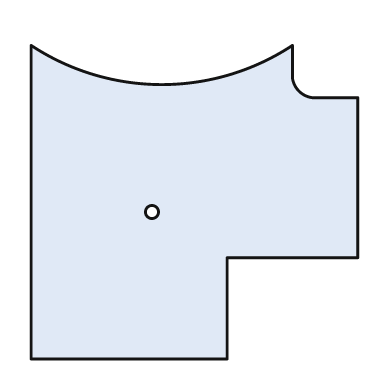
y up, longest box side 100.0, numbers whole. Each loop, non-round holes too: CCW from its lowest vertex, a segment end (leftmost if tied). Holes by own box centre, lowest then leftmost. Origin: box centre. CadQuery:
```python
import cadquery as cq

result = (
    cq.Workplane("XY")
    .moveTo(-50.0, -48.0)
    .lineTo(10.0, -48.0)
    .lineTo(10.0, -17.0)
    .lineTo(50.0, -17.0)
    .lineTo(50.0, 32.0)
    .lineTo(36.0, 32.0)
    .threePointArc((32.0, 34.0), (30.0, 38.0))
    .lineTo(30.0, 48.0)
    .threePointArc((-10.0, 36.0), (-50.0, 48.0))
    .close()
    .moveTo(-13.0, -3.0)
    .circle(2.0)
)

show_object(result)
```